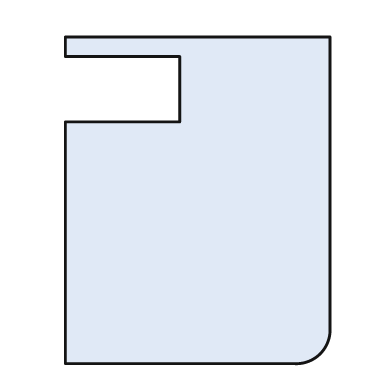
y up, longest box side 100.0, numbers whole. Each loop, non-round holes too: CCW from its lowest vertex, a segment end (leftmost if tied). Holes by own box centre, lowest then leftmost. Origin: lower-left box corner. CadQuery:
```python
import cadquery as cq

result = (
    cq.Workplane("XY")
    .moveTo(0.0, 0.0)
    .lineTo(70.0, 0.0)
    .threePointArc((78.0, 3.0), (81.0, 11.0))
    .lineTo(81.0, 100.0)
    .lineTo(0.0, 100.0)
    .lineTo(0.0, 94.0)
    .lineTo(35.0, 94.0)
    .lineTo(35.0, 74.0)
    .lineTo(0.0, 74.0)
    .close()
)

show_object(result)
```